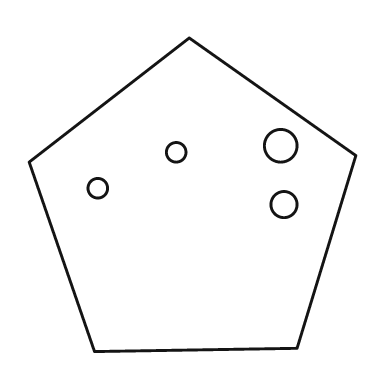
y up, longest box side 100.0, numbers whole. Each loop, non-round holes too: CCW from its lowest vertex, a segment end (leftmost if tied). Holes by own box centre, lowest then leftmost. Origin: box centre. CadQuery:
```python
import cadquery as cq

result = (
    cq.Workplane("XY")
    .moveTo(-30.0, -48.0)
    .lineTo(32.0, -47.0)
    .lineTo(50.0, 12.0)
    .lineTo(-1.0, 48.0)
    .lineTo(-50.0, 10.0)
    .close()
    .moveTo(28.0, -3.0)
    .circle(4.0)
    .moveTo(-29.0, 2.0)
    .circle(3.0)
    .moveTo(-5.0, 13.0)
    .circle(3.0)
    .moveTo(27.0, 15.0)
    .circle(5.0)
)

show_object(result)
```